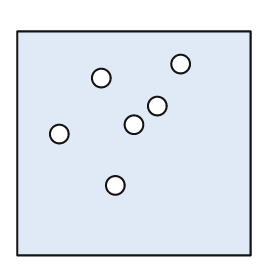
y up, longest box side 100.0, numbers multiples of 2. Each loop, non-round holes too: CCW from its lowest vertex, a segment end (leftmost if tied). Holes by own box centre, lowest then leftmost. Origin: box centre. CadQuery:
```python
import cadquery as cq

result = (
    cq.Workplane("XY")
    .moveTo(-50.0, -48.0)
    .lineTo(50.0, -48.0)
    .lineTo(50.0, 48.0)
    .lineTo(-50.0, 48.0)
    .close()
    .moveTo(-8.0, -18.0)
    .circle(4.0)
    .moveTo(-32.0, 4.0)
    .circle(4.0)
    .moveTo(0.0, 8.0)
    .circle(4.0)
    .moveTo(10.0, 16.0)
    .circle(4.0)
    .moveTo(-14.0, 28.0)
    .circle(4.0)
    .moveTo(20.0, 34.0)
    .circle(4.0)
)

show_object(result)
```